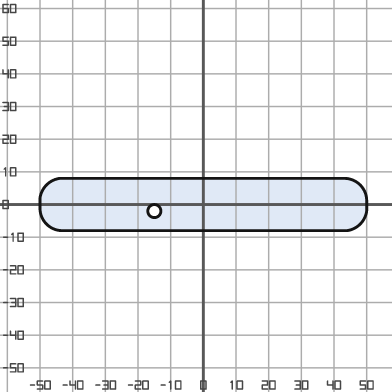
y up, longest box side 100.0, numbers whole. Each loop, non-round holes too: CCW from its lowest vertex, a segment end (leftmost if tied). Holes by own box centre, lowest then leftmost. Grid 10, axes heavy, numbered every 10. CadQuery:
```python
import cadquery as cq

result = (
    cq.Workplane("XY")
    .moveTo(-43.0, -8.0)
    .lineTo(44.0, -8.0)
    .threePointArc((48.0, -6.0), (50.0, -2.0))
    .lineTo(50.0, 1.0)
    .threePointArc((48.0, 6.0), (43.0, 8.0))
    .lineTo(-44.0, 8.0)
    .threePointArc((-48.0, 6.0), (-50.0, 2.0))
    .lineTo(-50.0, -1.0)
    .threePointArc((-48.0, -6.0), (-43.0, -8.0))
    .close()
    .moveTo(-15.0, -2.0)
    .circle(2.0)
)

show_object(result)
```